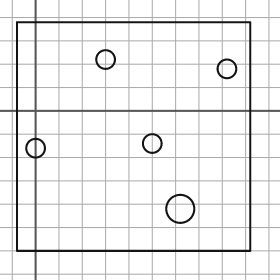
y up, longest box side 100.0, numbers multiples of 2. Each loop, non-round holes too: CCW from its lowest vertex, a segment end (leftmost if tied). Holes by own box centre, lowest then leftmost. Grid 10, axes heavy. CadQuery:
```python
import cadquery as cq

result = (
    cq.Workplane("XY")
    .moveTo(-8.0, -60.0)
    .lineTo(92.0, -60.0)
    .lineTo(92.0, 38.0)
    .lineTo(-8.0, 38.0)
    .close()
    .moveTo(62.0, -42.0)
    .circle(6.0)
    .moveTo(0.0, -16.0)
    .circle(4.0)
    .moveTo(50.0, -14.0)
    .circle(4.0)
    .moveTo(82.0, 18.0)
    .circle(4.0)
    .moveTo(30.0, 22.0)
    .circle(4.0)
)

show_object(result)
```